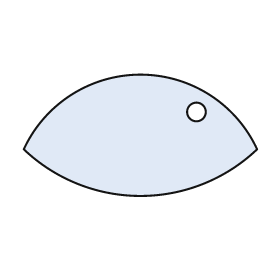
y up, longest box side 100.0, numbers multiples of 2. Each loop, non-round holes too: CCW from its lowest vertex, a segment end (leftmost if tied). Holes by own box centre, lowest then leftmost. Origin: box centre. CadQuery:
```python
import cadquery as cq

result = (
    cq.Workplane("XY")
    .moveTo(-50.0, -6.0)
    .threePointArc((0.0, -26.0), (50.0, -6.0))
    .threePointArc((0.0, 26.0), (-50.0, -6.0))
    .close()
    .moveTo(24.0, 10.0)
    .circle(4.0)
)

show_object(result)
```